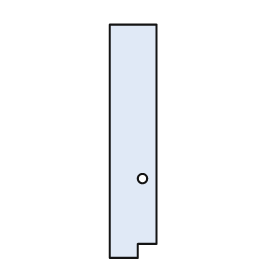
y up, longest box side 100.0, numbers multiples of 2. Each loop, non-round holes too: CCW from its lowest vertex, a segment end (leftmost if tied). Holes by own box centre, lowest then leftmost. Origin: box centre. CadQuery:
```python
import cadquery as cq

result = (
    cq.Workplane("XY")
    .moveTo(-10.0, -50.0)
    .lineTo(2.0, -50.0)
    .lineTo(2.0, -44.0)
    .lineTo(10.0, -44.0)
    .lineTo(10.0, 50.0)
    .lineTo(-10.0, 50.0)
    .close()
    .moveTo(4.0, -16.0)
    .circle(2.0)
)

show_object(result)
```